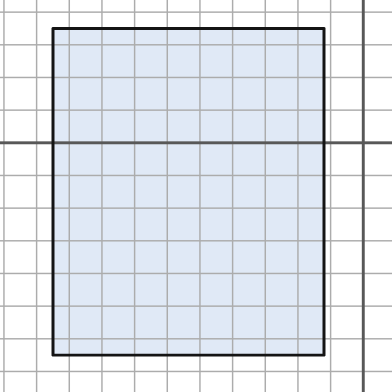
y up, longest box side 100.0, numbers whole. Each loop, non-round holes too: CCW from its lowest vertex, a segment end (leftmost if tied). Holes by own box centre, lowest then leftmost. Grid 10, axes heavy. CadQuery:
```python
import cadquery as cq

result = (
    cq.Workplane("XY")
    .moveTo(-95.0, -65.0)
    .lineTo(-12.0, -65.0)
    .lineTo(-12.0, 35.0)
    .lineTo(-95.0, 35.0)
    .close()
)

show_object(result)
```